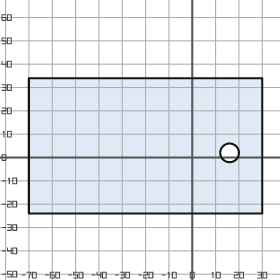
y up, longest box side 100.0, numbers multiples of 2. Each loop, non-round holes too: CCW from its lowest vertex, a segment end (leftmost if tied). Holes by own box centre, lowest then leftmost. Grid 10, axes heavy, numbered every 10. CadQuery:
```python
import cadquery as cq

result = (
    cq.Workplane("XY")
    .moveTo(-70.0, -24.0)
    .lineTo(30.0, -24.0)
    .lineTo(30.0, 34.0)
    .lineTo(-70.0, 34.0)
    .close()
    .moveTo(16.0, 2.0)
    .circle(4.0)
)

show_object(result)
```